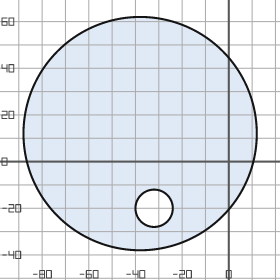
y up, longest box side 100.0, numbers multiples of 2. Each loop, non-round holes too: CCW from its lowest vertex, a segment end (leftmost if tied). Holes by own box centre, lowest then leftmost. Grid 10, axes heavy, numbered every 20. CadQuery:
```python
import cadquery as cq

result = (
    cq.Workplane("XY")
    .moveTo(-38.0, 12.0)
    .circle(50.0)
    .moveTo(-32.0, -20.0)
    .circle(8.0)
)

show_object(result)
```